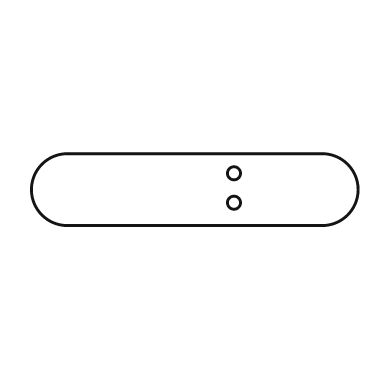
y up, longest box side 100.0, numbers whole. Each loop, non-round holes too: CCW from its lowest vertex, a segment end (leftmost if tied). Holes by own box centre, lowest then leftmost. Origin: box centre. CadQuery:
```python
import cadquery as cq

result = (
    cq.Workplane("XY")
    .moveTo(-39.0, -11.0)
    .lineTo(39.0, -11.0)
    .threePointArc((50.0, 0.0), (39.0, 11.0))
    .lineTo(-39.0, 11.0)
    .threePointArc((-50.0, 0.0), (-39.0, -11.0))
    .close()
    .moveTo(12.0, -4.0)
    .circle(2.0)
    .moveTo(12.0, 5.0)
    .circle(2.0)
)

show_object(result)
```